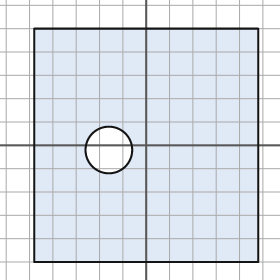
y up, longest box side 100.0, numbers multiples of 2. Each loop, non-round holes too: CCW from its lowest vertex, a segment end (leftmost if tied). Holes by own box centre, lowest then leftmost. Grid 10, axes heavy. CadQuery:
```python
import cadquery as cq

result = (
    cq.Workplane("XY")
    .moveTo(-48.0, -50.0)
    .lineTo(48.0, -50.0)
    .lineTo(48.0, 50.0)
    .lineTo(-48.0, 50.0)
    .close()
    .moveTo(-16.0, -2.0)
    .circle(10.0)
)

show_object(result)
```